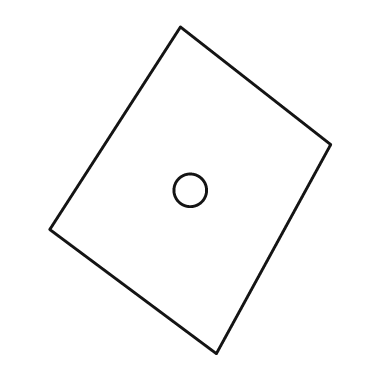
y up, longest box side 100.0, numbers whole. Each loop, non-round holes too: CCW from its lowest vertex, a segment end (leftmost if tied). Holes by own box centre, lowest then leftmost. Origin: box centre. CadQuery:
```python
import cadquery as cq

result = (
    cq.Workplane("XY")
    .moveTo(8.0, -50.0)
    .lineTo(43.0, 14.0)
    .lineTo(-3.0, 50.0)
    .lineTo(-43.0, -12.0)
    .close()
    .moveTo(0.0, 0.0)
    .circle(5.0)
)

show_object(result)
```